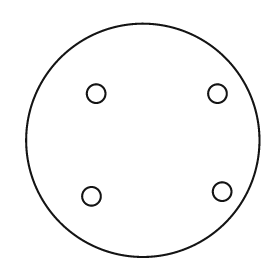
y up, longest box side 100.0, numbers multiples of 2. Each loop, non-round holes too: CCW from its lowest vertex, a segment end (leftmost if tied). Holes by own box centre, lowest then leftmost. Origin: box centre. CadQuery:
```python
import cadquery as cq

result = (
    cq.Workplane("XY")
    .moveTo(0.0, 0.0)
    .circle(50.0)
    .moveTo(-22.0, -24.0)
    .circle(4.0)
    .moveTo(34.0, -22.0)
    .circle(4.0)
    .moveTo(-20.0, 20.0)
    .circle(4.0)
    .moveTo(32.0, 20.0)
    .circle(4.0)
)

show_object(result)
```